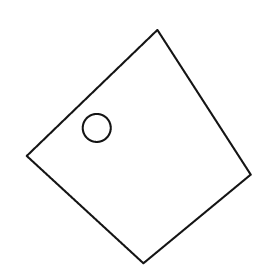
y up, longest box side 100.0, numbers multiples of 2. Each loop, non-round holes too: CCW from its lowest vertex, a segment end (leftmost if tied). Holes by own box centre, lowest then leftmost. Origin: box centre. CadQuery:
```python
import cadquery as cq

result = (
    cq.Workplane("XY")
    .moveTo(2.0, -50.0)
    .lineTo(48.0, -12.0)
    .lineTo(8.0, 50.0)
    .lineTo(-48.0, -4.0)
    .close()
    .moveTo(-18.0, 8.0)
    .circle(6.0)
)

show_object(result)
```